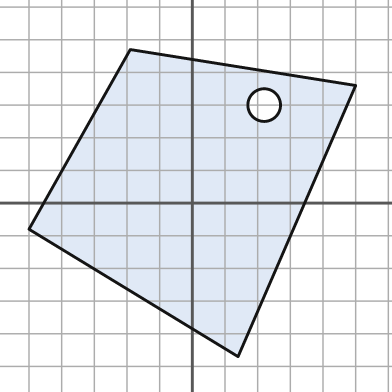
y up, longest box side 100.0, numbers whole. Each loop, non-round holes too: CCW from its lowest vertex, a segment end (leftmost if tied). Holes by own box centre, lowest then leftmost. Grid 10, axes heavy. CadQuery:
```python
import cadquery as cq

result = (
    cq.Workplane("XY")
    .moveTo(14.0, -47.0)
    .lineTo(50.0, 36.0)
    .lineTo(-19.0, 47.0)
    .lineTo(-50.0, -8.0)
    .close()
    .moveTo(22.0, 30.0)
    .circle(5.0)
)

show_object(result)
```